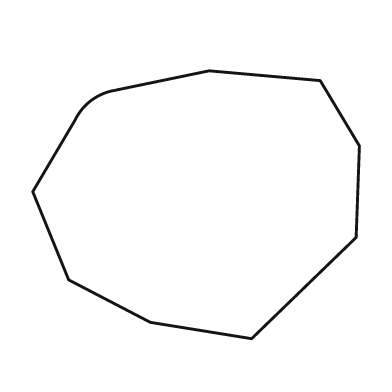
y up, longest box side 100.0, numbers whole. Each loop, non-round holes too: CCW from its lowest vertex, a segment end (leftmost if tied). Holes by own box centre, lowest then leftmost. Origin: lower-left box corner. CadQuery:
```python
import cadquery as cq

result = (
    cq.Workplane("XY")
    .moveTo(67.0, 0.0)
    .lineTo(99.0, 31.0)
    .lineTo(100.0, 59.0)
    .lineTo(88.0, 79.0)
    .lineTo(54.0, 82.0)
    .lineTo(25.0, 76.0)
    .threePointArc((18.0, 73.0), (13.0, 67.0))
    .lineTo(0.0, 45.0)
    .lineTo(11.0, 18.0)
    .lineTo(36.0, 5.0)
    .close()
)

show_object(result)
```